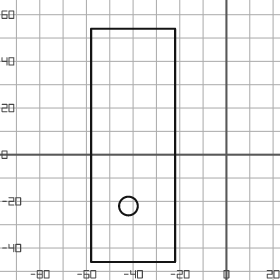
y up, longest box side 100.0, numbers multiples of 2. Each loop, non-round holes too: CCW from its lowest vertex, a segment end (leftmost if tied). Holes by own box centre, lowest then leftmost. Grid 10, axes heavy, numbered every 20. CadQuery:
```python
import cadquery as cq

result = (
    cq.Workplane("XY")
    .moveTo(-58.0, -46.0)
    .lineTo(-22.0, -46.0)
    .lineTo(-22.0, 54.0)
    .lineTo(-58.0, 54.0)
    .close()
    .moveTo(-42.0, -22.0)
    .circle(4.0)
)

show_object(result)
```